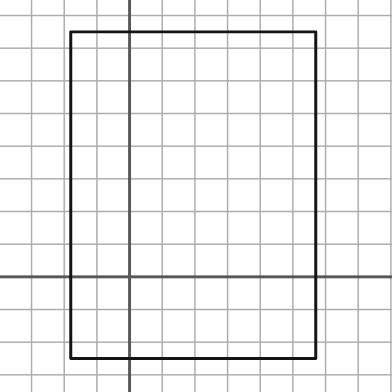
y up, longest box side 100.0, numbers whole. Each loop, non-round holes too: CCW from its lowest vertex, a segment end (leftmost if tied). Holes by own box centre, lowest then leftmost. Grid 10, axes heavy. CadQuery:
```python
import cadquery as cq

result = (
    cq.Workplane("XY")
    .moveTo(-18.0, -25.0)
    .lineTo(57.0, -25.0)
    .lineTo(57.0, 75.0)
    .lineTo(-18.0, 75.0)
    .close()
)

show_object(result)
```